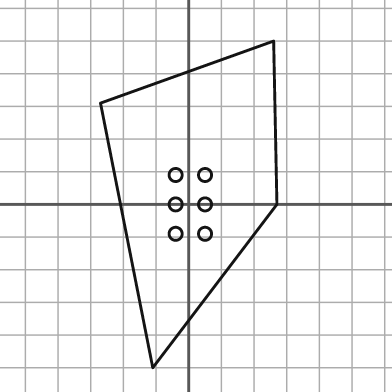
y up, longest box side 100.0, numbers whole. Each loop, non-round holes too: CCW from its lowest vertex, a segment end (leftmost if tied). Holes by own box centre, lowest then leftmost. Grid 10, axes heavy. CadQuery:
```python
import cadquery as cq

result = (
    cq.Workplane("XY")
    .moveTo(-11.0, -50.0)
    .lineTo(27.0, 0.0)
    .lineTo(26.0, 50.0)
    .lineTo(-27.0, 31.0)
    .close()
    .moveTo(-4.0, -9.0)
    .circle(2.0)
    .moveTo(5.0, -9.0)
    .circle(2.0)
    .moveTo(-4.0, 0.0)
    .circle(2.0)
    .moveTo(5.0, 0.0)
    .circle(2.0)
    .moveTo(-4.0, 9.0)
    .circle(2.0)
    .moveTo(5.0, 9.0)
    .circle(2.0)
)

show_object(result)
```